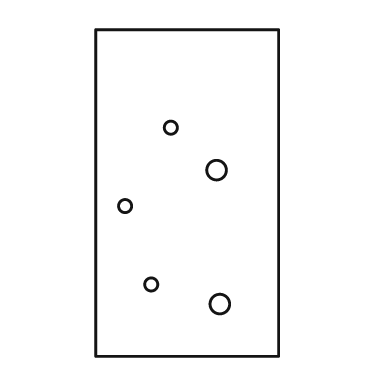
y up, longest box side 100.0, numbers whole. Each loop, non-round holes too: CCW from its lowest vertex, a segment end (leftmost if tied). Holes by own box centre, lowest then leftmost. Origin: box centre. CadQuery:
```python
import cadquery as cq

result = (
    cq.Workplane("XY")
    .moveTo(-28.0, -50.0)
    .lineTo(28.0, -50.0)
    .lineTo(28.0, 50.0)
    .lineTo(-28.0, 50.0)
    .close()
    .moveTo(10.0, -34.0)
    .circle(3.0)
    .moveTo(-11.0, -28.0)
    .circle(2.0)
    .moveTo(-19.0, -4.0)
    .circle(2.0)
    .moveTo(9.0, 7.0)
    .circle(3.0)
    .moveTo(-5.0, 20.0)
    .circle(2.0)
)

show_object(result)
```